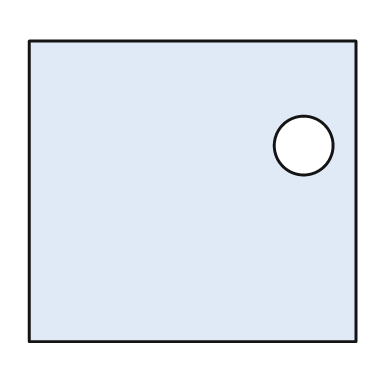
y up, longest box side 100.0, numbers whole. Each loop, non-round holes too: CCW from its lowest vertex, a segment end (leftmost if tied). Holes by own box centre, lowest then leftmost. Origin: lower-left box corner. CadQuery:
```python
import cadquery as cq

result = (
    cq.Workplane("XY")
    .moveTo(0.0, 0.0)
    .lineTo(100.0, 0.0)
    .lineTo(100.0, 92.0)
    .lineTo(0.0, 92.0)
    .close()
    .moveTo(84.0, 60.0)
    .circle(9.0)
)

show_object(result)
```